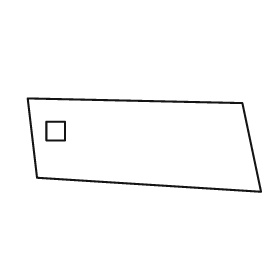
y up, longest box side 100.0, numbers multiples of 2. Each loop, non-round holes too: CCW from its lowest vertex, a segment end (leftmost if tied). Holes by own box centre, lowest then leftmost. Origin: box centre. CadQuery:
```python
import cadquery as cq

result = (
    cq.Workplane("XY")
    .moveTo(50.0, -20.0)
    .lineTo(42.0, 18.0)
    .lineTo(-50.0, 20.0)
    .lineTo(-46.0, -14.0)
    .close()
    .moveTo(-42.0, 2.0)
    .lineTo(-34.0, 2.0)
    .lineTo(-34.0, 10.0)
    .lineTo(-42.0, 10.0)
    .close()
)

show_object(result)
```